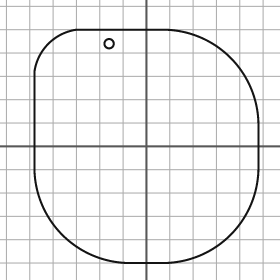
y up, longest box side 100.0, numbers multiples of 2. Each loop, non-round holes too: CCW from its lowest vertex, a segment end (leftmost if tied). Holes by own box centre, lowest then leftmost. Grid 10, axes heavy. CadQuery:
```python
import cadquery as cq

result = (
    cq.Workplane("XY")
    .moveTo(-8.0, -50.0)
    .lineTo(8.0, -50.0)
    .threePointArc((36.0, -38.0), (48.0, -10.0))
    .lineTo(48.0, 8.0)
    .threePointArc((36.0, 38.0), (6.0, 50.0))
    .lineTo(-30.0, 50.0)
    .threePointArc((-42.0, 44.0), (-48.0, 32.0))
    .lineTo(-48.0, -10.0)
    .threePointArc((-36.0, -38.0), (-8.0, -50.0))
    .close()
    .moveTo(-16.0, 44.0)
    .circle(2.0)
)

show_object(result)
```